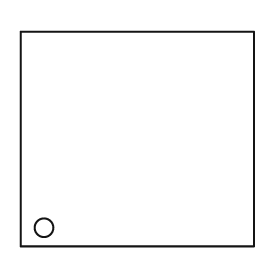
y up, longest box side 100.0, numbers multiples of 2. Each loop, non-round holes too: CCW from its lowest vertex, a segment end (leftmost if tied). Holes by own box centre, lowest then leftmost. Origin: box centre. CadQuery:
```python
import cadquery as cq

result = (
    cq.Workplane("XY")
    .moveTo(-50.0, -46.0)
    .lineTo(50.0, -46.0)
    .lineTo(50.0, 46.0)
    .lineTo(-50.0, 46.0)
    .close()
    .moveTo(-40.0, -38.0)
    .circle(4.0)
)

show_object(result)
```